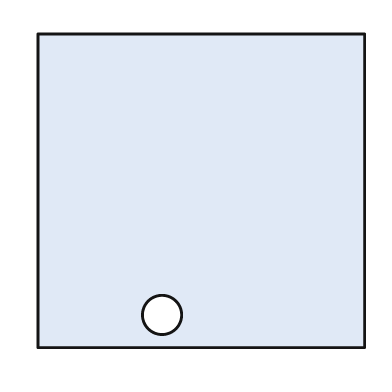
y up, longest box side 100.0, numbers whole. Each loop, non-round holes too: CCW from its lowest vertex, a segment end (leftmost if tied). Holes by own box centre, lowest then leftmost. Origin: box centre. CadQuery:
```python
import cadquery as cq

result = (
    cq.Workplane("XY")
    .moveTo(-50.0, -48.0)
    .lineTo(50.0, -48.0)
    .lineTo(50.0, 48.0)
    .lineTo(-50.0, 48.0)
    .close()
    .moveTo(-12.0, -38.0)
    .circle(6.0)
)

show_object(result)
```